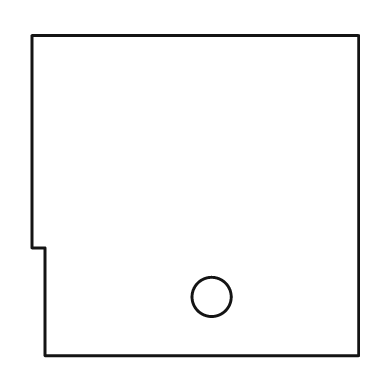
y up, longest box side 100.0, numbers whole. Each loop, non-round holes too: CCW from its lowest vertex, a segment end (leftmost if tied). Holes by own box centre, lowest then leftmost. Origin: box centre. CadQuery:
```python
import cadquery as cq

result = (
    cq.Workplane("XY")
    .moveTo(-46.0, -49.0)
    .lineTo(50.0, -49.0)
    .lineTo(50.0, 49.0)
    .lineTo(-50.0, 49.0)
    .lineTo(-50.0, -16.0)
    .lineTo(-46.0, -16.0)
    .close()
    .moveTo(5.0, -31.0)
    .circle(6.0)
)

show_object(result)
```